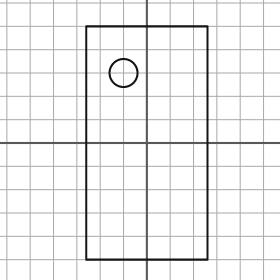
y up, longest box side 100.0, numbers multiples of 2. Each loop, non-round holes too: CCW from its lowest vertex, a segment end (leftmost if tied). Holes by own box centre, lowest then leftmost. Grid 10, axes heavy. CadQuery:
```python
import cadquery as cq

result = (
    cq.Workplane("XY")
    .moveTo(-26.0, -50.0)
    .lineTo(26.0, -50.0)
    .lineTo(26.0, 50.0)
    .lineTo(-26.0, 50.0)
    .close()
    .moveTo(-10.0, 30.0)
    .circle(6.0)
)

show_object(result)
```